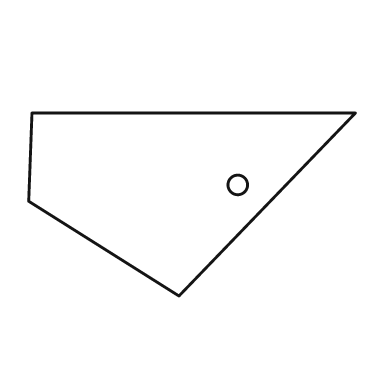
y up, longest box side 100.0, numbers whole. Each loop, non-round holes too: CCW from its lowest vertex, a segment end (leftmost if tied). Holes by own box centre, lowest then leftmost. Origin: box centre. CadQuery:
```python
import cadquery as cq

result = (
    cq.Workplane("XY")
    .moveTo(-4.0, -28.0)
    .lineTo(50.0, 28.0)
    .lineTo(-49.0, 28.0)
    .lineTo(-50.0, 1.0)
    .close()
    .moveTo(14.0, 6.0)
    .circle(3.0)
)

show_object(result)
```